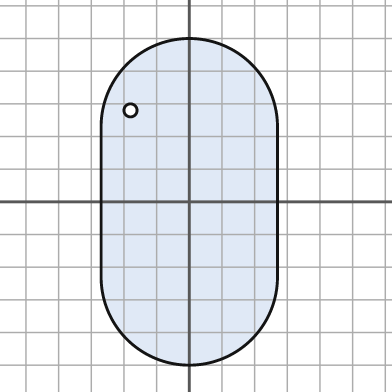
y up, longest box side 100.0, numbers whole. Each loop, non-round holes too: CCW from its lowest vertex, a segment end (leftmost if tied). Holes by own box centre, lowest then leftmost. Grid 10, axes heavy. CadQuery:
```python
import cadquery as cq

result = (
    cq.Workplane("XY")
    .moveTo(-27.0, -23.0)
    .threePointArc((0.0, -50.0), (27.0, -23.0))
    .lineTo(27.0, 23.0)
    .threePointArc((0.0, 50.0), (-27.0, 23.0))
    .close()
    .moveTo(-18.0, 28.0)
    .circle(2.0)
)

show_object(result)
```